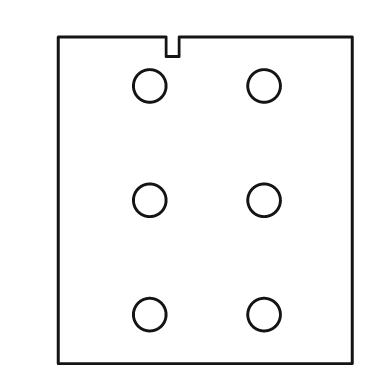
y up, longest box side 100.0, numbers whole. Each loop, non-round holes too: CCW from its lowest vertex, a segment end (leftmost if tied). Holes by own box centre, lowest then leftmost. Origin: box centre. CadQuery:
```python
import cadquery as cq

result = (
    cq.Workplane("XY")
    .moveTo(-45.0, -50.0)
    .lineTo(45.0, -50.0)
    .lineTo(45.0, 50.0)
    .lineTo(-8.0, 50.0)
    .lineTo(-8.0, 44.0)
    .lineTo(-12.0, 44.0)
    .lineTo(-12.0, 50.0)
    .lineTo(-45.0, 50.0)
    .close()
    .moveTo(-17.0, -35.0)
    .circle(5.0)
    .moveTo(18.0, -35.0)
    .circle(5.0)
    .moveTo(-17.0, 0.0)
    .circle(5.0)
    .moveTo(18.0, 0.0)
    .circle(5.0)
    .moveTo(-17.0, 35.0)
    .circle(5.0)
    .moveTo(18.0, 35.0)
    .circle(5.0)
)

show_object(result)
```